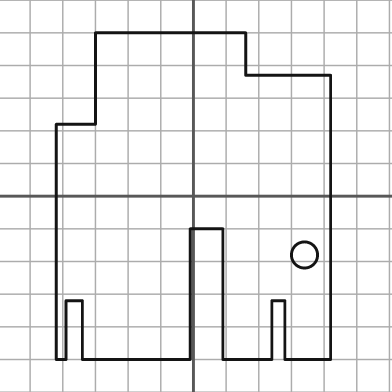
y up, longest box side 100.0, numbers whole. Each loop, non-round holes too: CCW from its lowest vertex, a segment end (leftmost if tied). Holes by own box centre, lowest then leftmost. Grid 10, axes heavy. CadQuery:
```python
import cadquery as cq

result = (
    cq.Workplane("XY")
    .moveTo(-42.0, -50.0)
    .lineTo(-39.0, -50.0)
    .lineTo(-39.0, -32.0)
    .lineTo(-34.0, -32.0)
    .lineTo(-34.0, -50.0)
    .lineTo(-1.0, -50.0)
    .lineTo(-1.0, -10.0)
    .lineTo(9.0, -10.0)
    .lineTo(9.0, -50.0)
    .lineTo(24.0, -50.0)
    .lineTo(24.0, -32.0)
    .lineTo(28.0, -32.0)
    .lineTo(28.0, -50.0)
    .lineTo(42.0, -50.0)
    .lineTo(42.0, 37.0)
    .lineTo(16.0, 37.0)
    .lineTo(16.0, 50.0)
    .lineTo(-30.0, 50.0)
    .lineTo(-30.0, 22.0)
    .lineTo(-42.0, 22.0)
    .close()
    .moveTo(34.0, -18.0)
    .circle(4.0)
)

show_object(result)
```